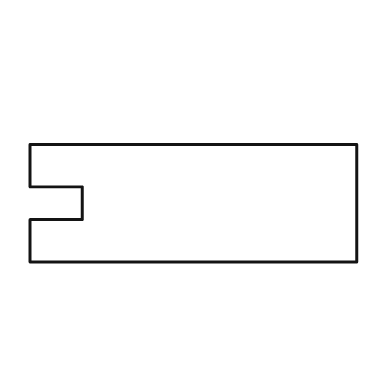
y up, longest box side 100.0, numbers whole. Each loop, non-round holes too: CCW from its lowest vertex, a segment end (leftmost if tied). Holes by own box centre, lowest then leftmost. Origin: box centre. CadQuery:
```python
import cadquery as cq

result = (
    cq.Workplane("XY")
    .moveTo(-50.0, -18.0)
    .lineTo(50.0, -18.0)
    .lineTo(50.0, 18.0)
    .lineTo(-50.0, 18.0)
    .lineTo(-50.0, 5.0)
    .lineTo(-34.0, 5.0)
    .lineTo(-34.0, -5.0)
    .lineTo(-50.0, -5.0)
    .close()
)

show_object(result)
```